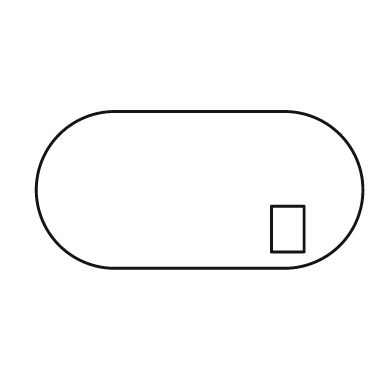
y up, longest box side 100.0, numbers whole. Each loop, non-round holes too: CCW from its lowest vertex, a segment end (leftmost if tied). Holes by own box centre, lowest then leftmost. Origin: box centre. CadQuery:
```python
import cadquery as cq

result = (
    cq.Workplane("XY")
    .moveTo(-26.0, -24.0)
    .lineTo(26.0, -24.0)
    .threePointArc((50.0, 0.0), (26.0, 24.0))
    .lineTo(-26.0, 24.0)
    .threePointArc((-50.0, 0.0), (-26.0, -24.0))
    .close()
    .moveTo(22.0, -19.0)
    .lineTo(32.0, -19.0)
    .lineTo(32.0, -5.0)
    .lineTo(22.0, -5.0)
    .close()
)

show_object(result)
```